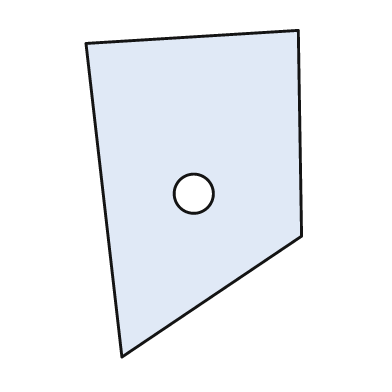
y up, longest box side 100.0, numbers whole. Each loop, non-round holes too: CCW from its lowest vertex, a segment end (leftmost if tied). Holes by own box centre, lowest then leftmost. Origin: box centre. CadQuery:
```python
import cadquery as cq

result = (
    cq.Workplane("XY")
    .moveTo(-22.0, -50.0)
    .lineTo(33.0, -13.0)
    .lineTo(32.0, 50.0)
    .lineTo(-33.0, 46.0)
    .close()
    .moveTo(0.0, 0.0)
    .circle(6.0)
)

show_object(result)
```